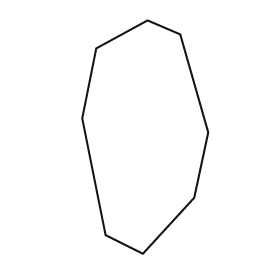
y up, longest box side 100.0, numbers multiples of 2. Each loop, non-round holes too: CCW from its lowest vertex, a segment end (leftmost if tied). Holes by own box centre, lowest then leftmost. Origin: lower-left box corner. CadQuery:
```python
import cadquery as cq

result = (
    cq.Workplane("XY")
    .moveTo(26.0, 0.0)
    .lineTo(48.0, 24.0)
    .lineTo(54.0, 52.0)
    .lineTo(42.0, 94.0)
    .lineTo(28.0, 100.0)
    .lineTo(6.0, 88.0)
    .lineTo(0.0, 58.0)
    .lineTo(10.0, 8.0)
    .close()
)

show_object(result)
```